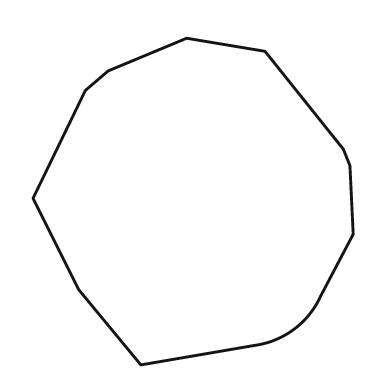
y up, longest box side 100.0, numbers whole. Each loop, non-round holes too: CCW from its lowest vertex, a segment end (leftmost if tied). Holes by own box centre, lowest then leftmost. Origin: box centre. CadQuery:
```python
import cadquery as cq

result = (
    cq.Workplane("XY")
    .moveTo(-16.0, -50.0)
    .lineTo(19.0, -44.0)
    .threePointArc((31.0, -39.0), (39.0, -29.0))
    .lineTo(49.0, -10.0)
    .lineTo(48.0, 11.0)
    .lineTo(46.0, 16.0)
    .lineTo(22.0, 46.0)
    .lineTo(-2.0, 50.0)
    .lineTo(-26.0, 40.0)
    .lineTo(-33.0, 34.0)
    .lineTo(-49.0, 1.0)
    .lineTo(-35.0, -27.0)
    .close()
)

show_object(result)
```